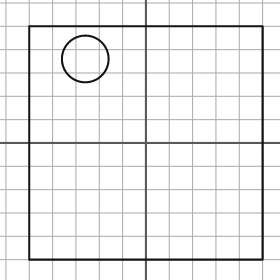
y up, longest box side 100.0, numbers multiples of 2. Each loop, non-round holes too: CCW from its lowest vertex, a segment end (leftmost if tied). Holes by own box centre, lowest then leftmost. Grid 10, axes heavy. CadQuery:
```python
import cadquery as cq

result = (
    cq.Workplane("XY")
    .moveTo(-50.0, -50.0)
    .lineTo(50.0, -50.0)
    .lineTo(50.0, 50.0)
    .lineTo(-50.0, 50.0)
    .close()
    .moveTo(-26.0, 36.0)
    .circle(10.0)
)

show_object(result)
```